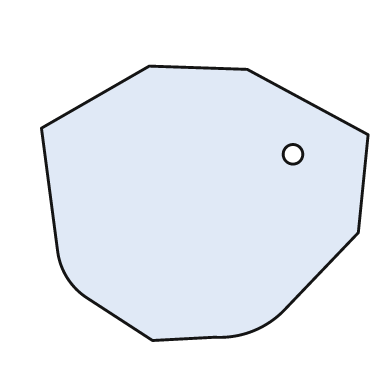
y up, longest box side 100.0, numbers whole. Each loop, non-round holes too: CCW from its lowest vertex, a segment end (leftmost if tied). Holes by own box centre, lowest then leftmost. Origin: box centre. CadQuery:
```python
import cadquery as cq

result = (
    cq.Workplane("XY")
    .moveTo(-16.0, -42.0)
    .lineTo(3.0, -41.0)
    .threePointArc((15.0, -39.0), (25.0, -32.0))
    .lineTo(47.0, -9.0)
    .lineTo(50.0, 21.0)
    .lineTo(13.0, 41.0)
    .lineTo(-17.0, 42.0)
    .lineTo(-50.0, 23.0)
    .lineTo(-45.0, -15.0)
    .threePointArc((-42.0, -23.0), (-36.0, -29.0))
    .close()
    .moveTo(27.0, 15.0)
    .circle(3.0)
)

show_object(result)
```